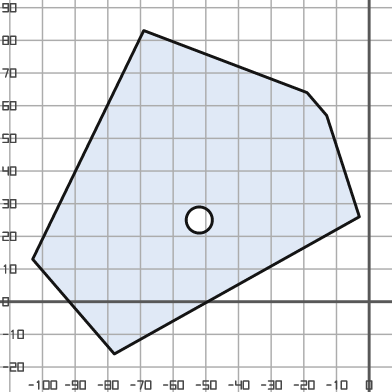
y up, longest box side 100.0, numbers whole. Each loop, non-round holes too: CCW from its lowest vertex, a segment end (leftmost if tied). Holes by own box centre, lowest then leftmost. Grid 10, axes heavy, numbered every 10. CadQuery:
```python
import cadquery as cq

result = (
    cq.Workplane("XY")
    .moveTo(-78.0, -16.0)
    .lineTo(-3.0, 26.0)
    .lineTo(-13.0, 57.0)
    .lineTo(-19.0, 64.0)
    .lineTo(-69.0, 83.0)
    .lineTo(-103.0, 13.0)
    .close()
    .moveTo(-52.0, 25.0)
    .circle(4.0)
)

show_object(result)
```